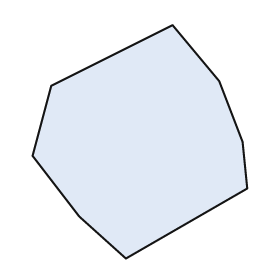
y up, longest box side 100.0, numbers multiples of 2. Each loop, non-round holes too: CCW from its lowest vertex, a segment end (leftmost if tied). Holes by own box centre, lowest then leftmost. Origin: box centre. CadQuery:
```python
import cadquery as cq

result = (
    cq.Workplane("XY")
    .moveTo(-6.0, -50.0)
    .lineTo(46.0, -20.0)
    .lineTo(44.0, 0.0)
    .lineTo(34.0, 26.0)
    .lineTo(14.0, 50.0)
    .lineTo(-38.0, 24.0)
    .lineTo(-46.0, -6.0)
    .lineTo(-26.0, -32.0)
    .close()
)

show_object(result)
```